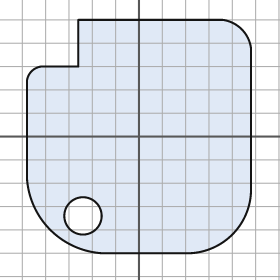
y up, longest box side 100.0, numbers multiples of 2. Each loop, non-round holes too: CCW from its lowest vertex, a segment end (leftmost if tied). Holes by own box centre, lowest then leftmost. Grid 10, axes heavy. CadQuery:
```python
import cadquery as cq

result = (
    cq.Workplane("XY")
    .moveTo(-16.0, -50.0)
    .lineTo(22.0, -50.0)
    .threePointArc((40.0, -42.0), (48.0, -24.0))
    .lineTo(48.0, 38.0)
    .threePointArc((44.0, 46.0), (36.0, 50.0))
    .lineTo(-26.0, 50.0)
    .lineTo(-26.0, 30.0)
    .lineTo(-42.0, 30.0)
    .threePointArc((-46.0, 28.0), (-48.0, 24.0))
    .lineTo(-48.0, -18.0)
    .threePointArc((-38.0, -40.0), (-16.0, -50.0))
    .close()
    .moveTo(-24.0, -34.0)
    .circle(8.0)
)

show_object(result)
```